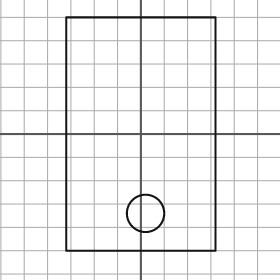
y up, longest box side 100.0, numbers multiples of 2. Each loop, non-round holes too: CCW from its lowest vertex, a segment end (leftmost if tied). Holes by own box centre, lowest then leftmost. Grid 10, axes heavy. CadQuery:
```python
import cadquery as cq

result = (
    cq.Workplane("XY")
    .moveTo(-32.0, -50.0)
    .lineTo(32.0, -50.0)
    .lineTo(32.0, 50.0)
    .lineTo(-32.0, 50.0)
    .close()
    .moveTo(2.0, -34.0)
    .circle(8.0)
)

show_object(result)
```